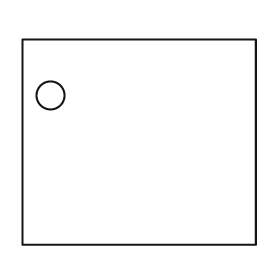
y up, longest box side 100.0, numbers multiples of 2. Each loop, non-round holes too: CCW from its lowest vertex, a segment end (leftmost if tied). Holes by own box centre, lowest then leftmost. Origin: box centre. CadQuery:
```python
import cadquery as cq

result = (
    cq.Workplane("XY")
    .moveTo(-50.0, -44.0)
    .lineTo(50.0, -44.0)
    .lineTo(50.0, 44.0)
    .lineTo(-50.0, 44.0)
    .close()
    .moveTo(-38.0, 20.0)
    .circle(6.0)
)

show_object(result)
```